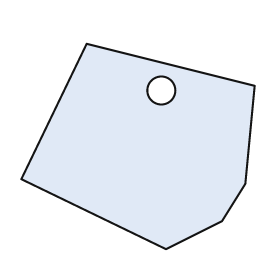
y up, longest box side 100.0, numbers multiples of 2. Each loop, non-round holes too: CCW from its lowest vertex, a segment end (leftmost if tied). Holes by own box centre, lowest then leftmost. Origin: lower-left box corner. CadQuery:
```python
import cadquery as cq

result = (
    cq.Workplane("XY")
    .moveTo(62.0, 0.0)
    .lineTo(86.0, 12.0)
    .lineTo(96.0, 28.0)
    .lineTo(100.0, 70.0)
    .lineTo(28.0, 88.0)
    .lineTo(0.0, 30.0)
    .close()
    .moveTo(60.0, 68.0)
    .circle(6.0)
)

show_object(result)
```